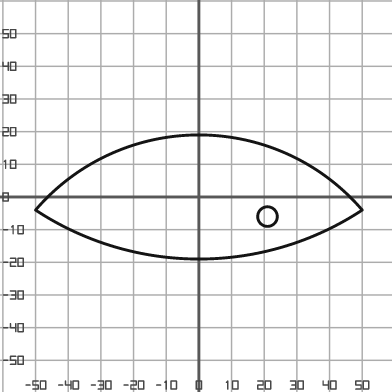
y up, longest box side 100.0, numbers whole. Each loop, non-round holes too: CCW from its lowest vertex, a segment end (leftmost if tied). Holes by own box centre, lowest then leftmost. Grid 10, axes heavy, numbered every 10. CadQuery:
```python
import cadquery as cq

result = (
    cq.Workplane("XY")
    .moveTo(-50.0, -4.0)
    .threePointArc((0.0, -19.0), (50.0, -4.0))
    .threePointArc((0.0, 19.0), (-50.0, -4.0))
    .close()
    .moveTo(21.0, -6.0)
    .circle(3.0)
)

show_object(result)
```